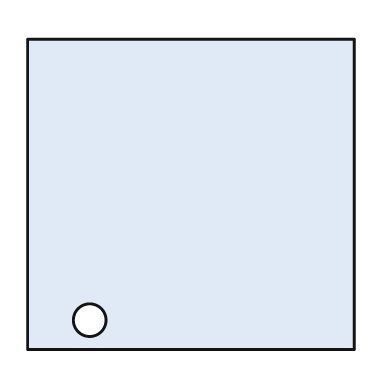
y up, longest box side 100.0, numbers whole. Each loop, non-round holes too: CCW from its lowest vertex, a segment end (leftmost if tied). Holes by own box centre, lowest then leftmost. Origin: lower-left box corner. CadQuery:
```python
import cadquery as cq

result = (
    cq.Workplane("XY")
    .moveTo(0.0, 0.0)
    .lineTo(100.0, 0.0)
    .lineTo(100.0, 95.0)
    .lineTo(0.0, 95.0)
    .close()
    .moveTo(19.0, 9.0)
    .circle(5.0)
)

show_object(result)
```